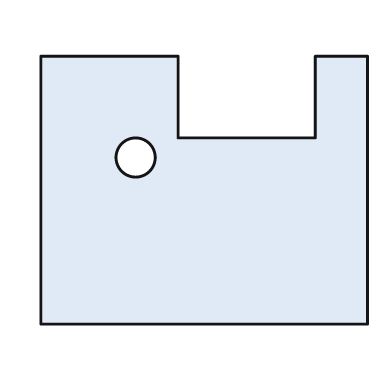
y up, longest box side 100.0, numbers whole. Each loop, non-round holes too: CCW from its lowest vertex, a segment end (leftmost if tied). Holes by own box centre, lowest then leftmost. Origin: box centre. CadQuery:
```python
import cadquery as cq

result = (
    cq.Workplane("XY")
    .moveTo(-50.0, -41.0)
    .lineTo(50.0, -41.0)
    .lineTo(50.0, 41.0)
    .lineTo(34.0, 41.0)
    .lineTo(34.0, 16.0)
    .lineTo(-8.0, 16.0)
    .lineTo(-8.0, 41.0)
    .lineTo(-50.0, 41.0)
    .close()
    .moveTo(-21.0, 10.0)
    .circle(6.0)
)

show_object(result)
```